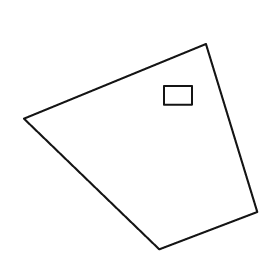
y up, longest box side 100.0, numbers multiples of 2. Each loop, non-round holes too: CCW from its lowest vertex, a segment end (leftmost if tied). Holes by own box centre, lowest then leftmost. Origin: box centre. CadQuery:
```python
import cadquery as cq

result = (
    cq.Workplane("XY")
    .moveTo(8.0, -44.0)
    .lineTo(50.0, -28.0)
    .lineTo(28.0, 44.0)
    .lineTo(-50.0, 12.0)
    .close()
    .moveTo(10.0, 18.0)
    .lineTo(22.0, 18.0)
    .lineTo(22.0, 26.0)
    .lineTo(10.0, 26.0)
    .close()
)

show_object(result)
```